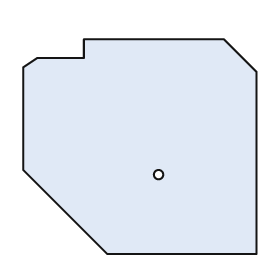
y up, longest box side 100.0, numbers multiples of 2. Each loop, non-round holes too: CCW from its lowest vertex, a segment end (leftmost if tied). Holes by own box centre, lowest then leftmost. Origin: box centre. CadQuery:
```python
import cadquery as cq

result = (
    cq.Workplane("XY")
    .moveTo(-14.0, -46.0)
    .lineTo(50.0, -46.0)
    .lineTo(50.0, 32.0)
    .lineTo(36.0, 46.0)
    .lineTo(-24.0, 46.0)
    .lineTo(-24.0, 38.0)
    .lineTo(-44.0, 38.0)
    .lineTo(-50.0, 34.0)
    .lineTo(-50.0, -10.0)
    .close()
    .moveTo(8.0, -12.0)
    .circle(2.0)
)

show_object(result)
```